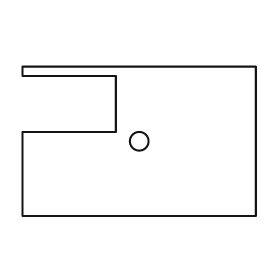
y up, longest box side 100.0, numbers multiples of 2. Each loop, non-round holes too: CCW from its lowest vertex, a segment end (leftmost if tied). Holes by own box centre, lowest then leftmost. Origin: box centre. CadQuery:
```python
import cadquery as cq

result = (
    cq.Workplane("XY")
    .moveTo(-50.0, -32.0)
    .lineTo(50.0, -32.0)
    .lineTo(50.0, 32.0)
    .lineTo(-50.0, 32.0)
    .lineTo(-50.0, 28.0)
    .lineTo(-10.0, 28.0)
    .lineTo(-10.0, 4.0)
    .lineTo(-50.0, 4.0)
    .close()
    .moveTo(0.0, 0.0)
    .circle(4.0)
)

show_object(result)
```